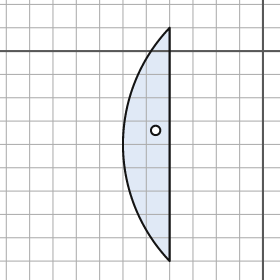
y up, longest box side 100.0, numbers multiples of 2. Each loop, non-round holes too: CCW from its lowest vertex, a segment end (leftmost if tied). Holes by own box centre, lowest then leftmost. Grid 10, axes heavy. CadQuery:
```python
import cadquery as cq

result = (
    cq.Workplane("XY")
    .moveTo(-40.0, -90.0)
    .lineTo(-40.0, 10.0)
    .threePointArc((-60.0, -40.0), (-40.0, -90.0))
    .close()
    .moveTo(-46.0, -34.0)
    .circle(2.0)
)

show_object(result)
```